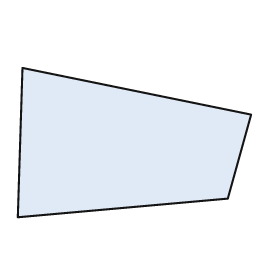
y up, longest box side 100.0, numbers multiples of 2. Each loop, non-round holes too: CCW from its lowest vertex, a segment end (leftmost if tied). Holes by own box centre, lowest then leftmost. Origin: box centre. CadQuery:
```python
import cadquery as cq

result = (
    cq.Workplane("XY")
    .moveTo(-50.0, -32.0)
    .lineTo(40.0, -24.0)
    .lineTo(50.0, 12.0)
    .lineTo(-48.0, 32.0)
    .close()
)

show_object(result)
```